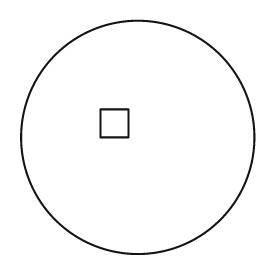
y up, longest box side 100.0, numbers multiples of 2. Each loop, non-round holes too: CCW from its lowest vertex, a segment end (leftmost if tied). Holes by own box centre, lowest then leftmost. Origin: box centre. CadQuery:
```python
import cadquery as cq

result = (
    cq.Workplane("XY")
    .moveTo(0.0, 0.0)
    .circle(50.0)
    .moveTo(-16.0, 0.0)
    .lineTo(-4.0, 0.0)
    .lineTo(-4.0, 12.0)
    .lineTo(-16.0, 12.0)
    .close()
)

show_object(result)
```